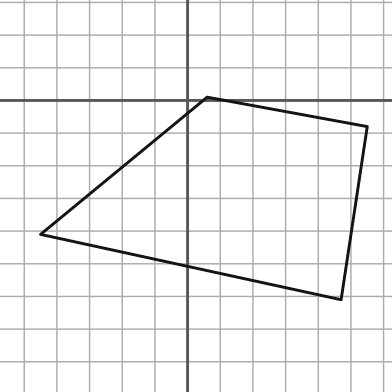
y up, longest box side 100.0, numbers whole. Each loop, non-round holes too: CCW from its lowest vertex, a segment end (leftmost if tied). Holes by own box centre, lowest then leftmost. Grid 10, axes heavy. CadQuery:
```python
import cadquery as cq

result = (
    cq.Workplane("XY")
    .moveTo(47.0, -61.0)
    .lineTo(55.0, -8.0)
    .lineTo(6.0, 1.0)
    .lineTo(-45.0, -41.0)
    .close()
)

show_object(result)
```